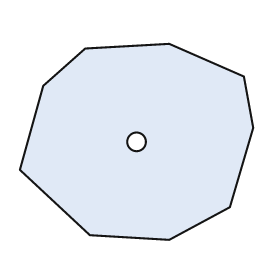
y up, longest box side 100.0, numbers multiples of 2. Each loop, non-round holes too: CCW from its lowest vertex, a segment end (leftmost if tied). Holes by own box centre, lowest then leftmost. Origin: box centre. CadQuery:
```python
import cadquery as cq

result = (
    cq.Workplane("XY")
    .moveTo(14.0, -42.0)
    .lineTo(40.0, -28.0)
    .lineTo(50.0, 6.0)
    .lineTo(46.0, 28.0)
    .lineTo(14.0, 42.0)
    .lineTo(-22.0, 40.0)
    .lineTo(-40.0, 24.0)
    .lineTo(-50.0, -12.0)
    .lineTo(-20.0, -40.0)
    .close()
    .moveTo(0.0, 0.0)
    .circle(4.0)
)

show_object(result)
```